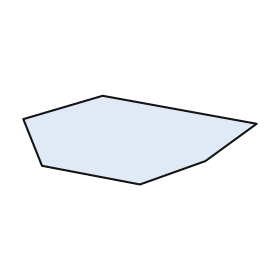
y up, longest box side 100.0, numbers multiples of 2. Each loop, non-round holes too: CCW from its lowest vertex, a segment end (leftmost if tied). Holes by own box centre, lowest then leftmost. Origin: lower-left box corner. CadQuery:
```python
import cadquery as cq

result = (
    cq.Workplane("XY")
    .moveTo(50.0, 0.0)
    .lineTo(78.0, 10.0)
    .lineTo(100.0, 26.0)
    .lineTo(34.0, 38.0)
    .lineTo(0.0, 28.0)
    .lineTo(8.0, 8.0)
    .close()
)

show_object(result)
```